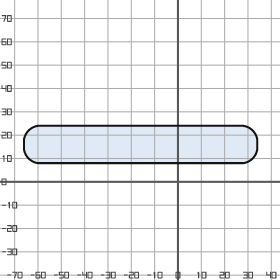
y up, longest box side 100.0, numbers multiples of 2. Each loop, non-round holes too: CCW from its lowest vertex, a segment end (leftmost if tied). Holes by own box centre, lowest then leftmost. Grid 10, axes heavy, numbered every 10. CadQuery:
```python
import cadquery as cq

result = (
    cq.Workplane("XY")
    .moveTo(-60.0, 8.0)
    .lineTo(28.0, 8.0)
    .threePointArc((32.0, 10.0), (34.0, 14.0))
    .lineTo(34.0, 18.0)
    .threePointArc((32.0, 22.0), (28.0, 24.0))
    .lineTo(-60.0, 24.0)
    .threePointArc((-64.0, 22.0), (-66.0, 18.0))
    .lineTo(-66.0, 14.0)
    .threePointArc((-64.0, 10.0), (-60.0, 8.0))
    .close()
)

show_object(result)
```